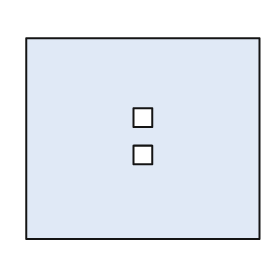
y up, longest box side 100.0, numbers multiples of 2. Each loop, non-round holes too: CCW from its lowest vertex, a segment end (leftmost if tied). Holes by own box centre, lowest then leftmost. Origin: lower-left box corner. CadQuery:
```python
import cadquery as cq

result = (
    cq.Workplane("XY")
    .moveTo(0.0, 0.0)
    .lineTo(100.0, 0.0)
    .lineTo(100.0, 86.0)
    .lineTo(0.0, 86.0)
    .close()
    .moveTo(46.0, 32.0)
    .lineTo(54.0, 32.0)
    .lineTo(54.0, 40.0)
    .lineTo(46.0, 40.0)
    .close()
    .moveTo(46.0, 48.0)
    .lineTo(54.0, 48.0)
    .lineTo(54.0, 56.0)
    .lineTo(46.0, 56.0)
    .close()
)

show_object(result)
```